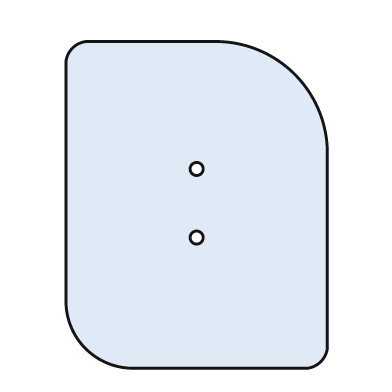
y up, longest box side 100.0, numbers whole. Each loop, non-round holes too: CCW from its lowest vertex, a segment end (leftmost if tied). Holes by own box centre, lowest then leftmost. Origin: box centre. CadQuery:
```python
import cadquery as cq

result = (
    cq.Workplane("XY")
    .moveTo(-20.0, -50.0)
    .lineTo(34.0, -50.0)
    .threePointArc((38.0, -48.0), (40.0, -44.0))
    .lineTo(40.0, 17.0)
    .threePointArc((30.0, 40.0), (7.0, 50.0))
    .lineTo(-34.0, 50.0)
    .threePointArc((-38.0, 48.0), (-40.0, 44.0))
    .lineTo(-40.0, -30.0)
    .threePointArc((-34.0, -44.0), (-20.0, -50.0))
    .close()
    .moveTo(0.0, -10.0)
    .circle(2.0)
    .moveTo(0.0, 11.0)
    .circle(2.0)
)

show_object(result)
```